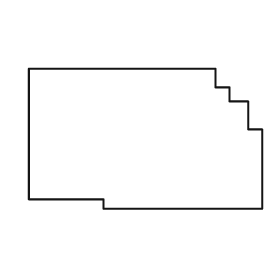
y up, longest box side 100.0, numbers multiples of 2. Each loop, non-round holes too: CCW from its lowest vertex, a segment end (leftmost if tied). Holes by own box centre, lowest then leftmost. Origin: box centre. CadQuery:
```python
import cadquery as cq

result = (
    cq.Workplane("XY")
    .moveTo(-18.0, -30.0)
    .lineTo(50.0, -30.0)
    .lineTo(50.0, 4.0)
    .lineTo(44.0, 4.0)
    .lineTo(44.0, 16.0)
    .lineTo(36.0, 16.0)
    .lineTo(36.0, 22.0)
    .lineTo(30.0, 22.0)
    .lineTo(30.0, 30.0)
    .lineTo(-50.0, 30.0)
    .lineTo(-50.0, -26.0)
    .lineTo(-18.0, -26.0)
    .close()
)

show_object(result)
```